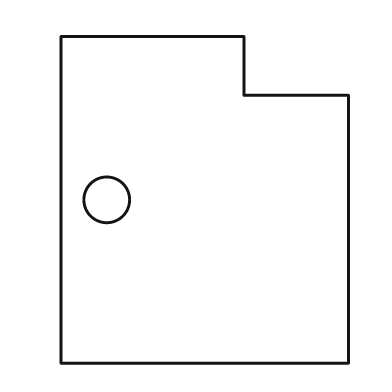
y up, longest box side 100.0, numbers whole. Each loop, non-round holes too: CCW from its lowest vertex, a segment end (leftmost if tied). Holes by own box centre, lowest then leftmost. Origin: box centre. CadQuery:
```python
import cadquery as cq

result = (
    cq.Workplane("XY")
    .moveTo(-44.0, -50.0)
    .lineTo(44.0, -50.0)
    .lineTo(44.0, 32.0)
    .lineTo(12.0, 32.0)
    .lineTo(12.0, 50.0)
    .lineTo(-44.0, 50.0)
    .close()
    .moveTo(-30.0, 0.0)
    .circle(7.0)
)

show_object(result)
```